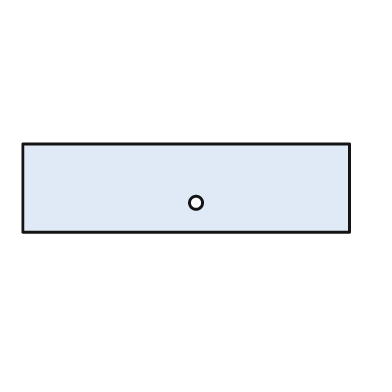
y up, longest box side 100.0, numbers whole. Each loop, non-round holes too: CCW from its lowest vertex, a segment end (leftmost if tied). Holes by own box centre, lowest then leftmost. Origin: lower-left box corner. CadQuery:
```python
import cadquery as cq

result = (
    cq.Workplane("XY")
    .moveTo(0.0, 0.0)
    .lineTo(100.0, 0.0)
    .lineTo(100.0, 27.0)
    .lineTo(0.0, 27.0)
    .close()
    .moveTo(53.0, 9.0)
    .circle(2.0)
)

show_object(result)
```